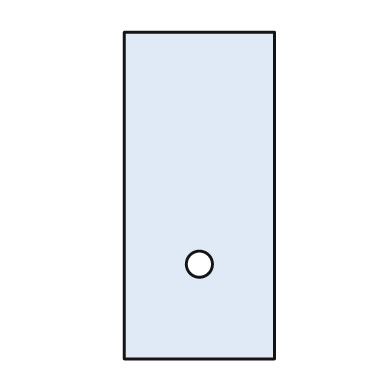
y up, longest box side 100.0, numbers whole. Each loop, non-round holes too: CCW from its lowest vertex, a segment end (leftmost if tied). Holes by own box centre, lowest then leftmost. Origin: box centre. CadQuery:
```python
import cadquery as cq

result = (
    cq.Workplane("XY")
    .moveTo(-23.0, -50.0)
    .lineTo(23.0, -50.0)
    .lineTo(23.0, 50.0)
    .lineTo(-23.0, 50.0)
    .close()
    .moveTo(0.0, -21.0)
    .circle(4.0)
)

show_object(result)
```